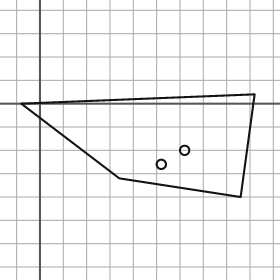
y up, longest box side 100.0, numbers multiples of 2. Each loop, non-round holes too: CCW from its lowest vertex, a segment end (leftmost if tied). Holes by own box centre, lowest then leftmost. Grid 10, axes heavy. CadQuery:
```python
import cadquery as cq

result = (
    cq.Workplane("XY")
    .moveTo(86.0, -40.0)
    .lineTo(92.0, 4.0)
    .lineTo(-8.0, 0.0)
    .lineTo(34.0, -32.0)
    .close()
    .moveTo(52.0, -26.0)
    .circle(2.0)
    .moveTo(62.0, -20.0)
    .circle(2.0)
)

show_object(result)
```